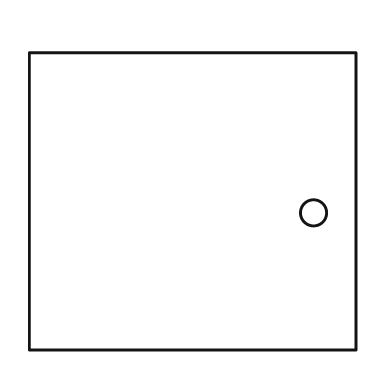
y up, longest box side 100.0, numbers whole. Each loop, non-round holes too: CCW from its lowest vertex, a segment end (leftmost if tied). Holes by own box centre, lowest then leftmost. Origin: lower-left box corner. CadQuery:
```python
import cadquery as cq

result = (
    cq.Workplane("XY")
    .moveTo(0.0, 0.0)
    .lineTo(100.0, 0.0)
    .lineTo(100.0, 91.0)
    .lineTo(0.0, 91.0)
    .close()
    .moveTo(87.0, 42.0)
    .circle(4.0)
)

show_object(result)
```